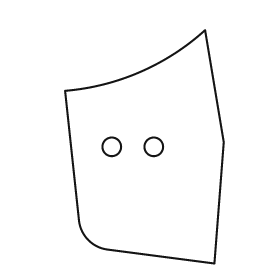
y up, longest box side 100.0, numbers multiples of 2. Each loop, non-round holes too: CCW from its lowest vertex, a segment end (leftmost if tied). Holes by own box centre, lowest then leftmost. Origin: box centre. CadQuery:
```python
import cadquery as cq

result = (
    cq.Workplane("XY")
    .moveTo(30.0, -50.0)
    .lineTo(34.0, 2.0)
    .lineTo(26.0, 50.0)
    .threePointArc((-2.0, 32.0), (-34.0, 24.0))
    .lineTo(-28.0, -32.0)
    .threePointArc((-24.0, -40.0), (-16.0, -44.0))
    .close()
    .moveTo(-14.0, 0.0)
    .circle(4.0)
    .moveTo(4.0, 0.0)
    .circle(4.0)
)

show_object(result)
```